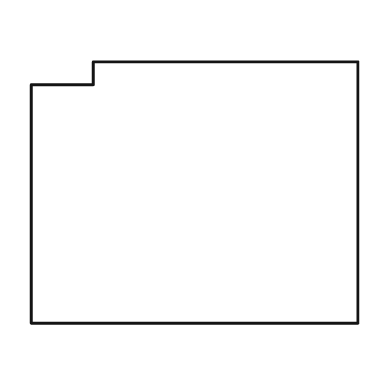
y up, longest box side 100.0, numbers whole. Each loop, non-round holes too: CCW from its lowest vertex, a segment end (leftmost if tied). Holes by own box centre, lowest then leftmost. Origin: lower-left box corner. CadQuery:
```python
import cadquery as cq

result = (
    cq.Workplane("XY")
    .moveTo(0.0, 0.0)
    .lineTo(100.0, 0.0)
    .lineTo(100.0, 80.0)
    .lineTo(19.0, 80.0)
    .lineTo(19.0, 73.0)
    .lineTo(0.0, 73.0)
    .close()
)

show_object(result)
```